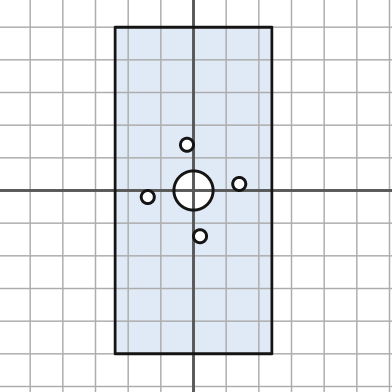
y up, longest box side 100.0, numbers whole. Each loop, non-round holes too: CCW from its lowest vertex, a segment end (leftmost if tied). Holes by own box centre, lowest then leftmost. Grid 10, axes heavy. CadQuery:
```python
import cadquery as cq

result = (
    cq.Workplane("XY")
    .moveTo(-24.0, -50.0)
    .lineTo(24.0, -50.0)
    .lineTo(24.0, 50.0)
    .lineTo(-24.0, 50.0)
    .close()
    .moveTo(2.0, -14.0)
    .circle(2.0)
    .moveTo(-14.0, -2.0)
    .circle(2.0)
    .moveTo(0.0, 0.0)
    .circle(6.0)
    .moveTo(14.0, 2.0)
    .circle(2.0)
    .moveTo(-2.0, 14.0)
    .circle(2.0)
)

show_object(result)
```